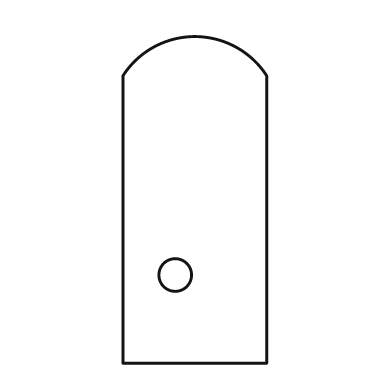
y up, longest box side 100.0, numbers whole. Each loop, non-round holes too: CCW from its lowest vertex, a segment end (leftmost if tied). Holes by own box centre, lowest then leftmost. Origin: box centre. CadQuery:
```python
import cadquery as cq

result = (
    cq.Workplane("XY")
    .moveTo(-22.0, -50.0)
    .lineTo(22.0, -50.0)
    .lineTo(22.0, 38.0)
    .threePointArc((0.0, 50.0), (-22.0, 38.0))
    .close()
    .moveTo(-6.0, -23.0)
    .circle(5.0)
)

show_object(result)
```